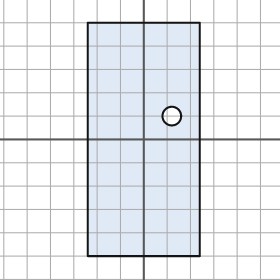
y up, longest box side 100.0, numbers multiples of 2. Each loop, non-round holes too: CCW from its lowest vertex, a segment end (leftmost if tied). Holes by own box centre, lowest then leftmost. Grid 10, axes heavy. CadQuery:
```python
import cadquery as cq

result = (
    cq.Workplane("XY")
    .moveTo(-24.0, -50.0)
    .lineTo(24.0, -50.0)
    .lineTo(24.0, 50.0)
    .lineTo(-24.0, 50.0)
    .close()
    .moveTo(12.0, 10.0)
    .circle(4.0)
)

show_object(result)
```